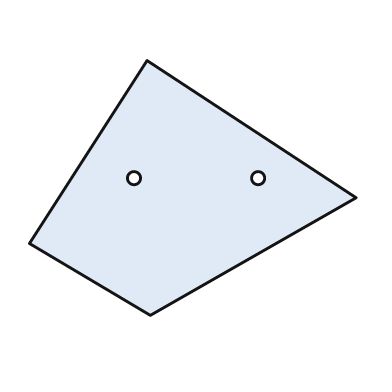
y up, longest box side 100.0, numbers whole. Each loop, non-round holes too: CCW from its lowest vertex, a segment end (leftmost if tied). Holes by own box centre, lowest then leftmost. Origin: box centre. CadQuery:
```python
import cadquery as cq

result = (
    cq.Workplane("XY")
    .moveTo(-13.0, -39.0)
    .lineTo(50.0, -3.0)
    .lineTo(-14.0, 39.0)
    .lineTo(-50.0, -17.0)
    .close()
    .moveTo(-18.0, 3.0)
    .circle(2.0)
    .moveTo(20.0, 3.0)
    .circle(2.0)
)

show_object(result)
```